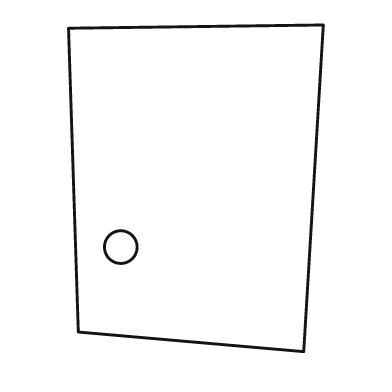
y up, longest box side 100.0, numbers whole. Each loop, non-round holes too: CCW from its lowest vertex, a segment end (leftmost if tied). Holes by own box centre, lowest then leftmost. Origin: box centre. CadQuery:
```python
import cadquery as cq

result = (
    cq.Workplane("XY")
    .moveTo(33.0, -50.0)
    .lineTo(39.0, 50.0)
    .lineTo(-39.0, 49.0)
    .lineTo(-36.0, -44.0)
    .close()
    .moveTo(-23.0, -18.0)
    .circle(5.0)
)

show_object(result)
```